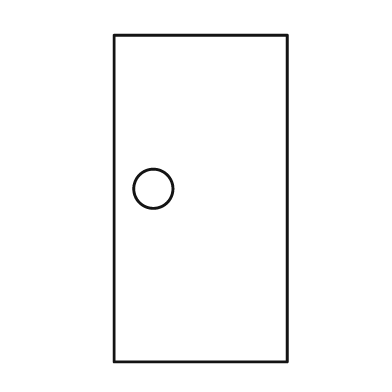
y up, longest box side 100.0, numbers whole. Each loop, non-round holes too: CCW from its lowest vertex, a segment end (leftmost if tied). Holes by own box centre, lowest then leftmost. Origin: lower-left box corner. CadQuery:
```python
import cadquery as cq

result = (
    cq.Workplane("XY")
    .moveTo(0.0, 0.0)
    .lineTo(53.0, 0.0)
    .lineTo(53.0, 100.0)
    .lineTo(0.0, 100.0)
    .close()
    .moveTo(12.0, 53.0)
    .circle(6.0)
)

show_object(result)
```